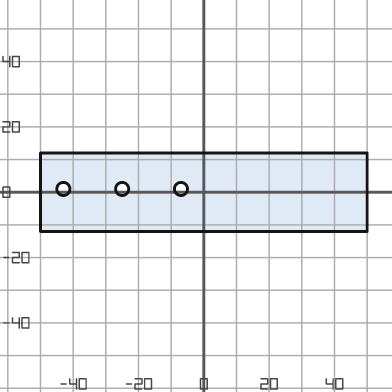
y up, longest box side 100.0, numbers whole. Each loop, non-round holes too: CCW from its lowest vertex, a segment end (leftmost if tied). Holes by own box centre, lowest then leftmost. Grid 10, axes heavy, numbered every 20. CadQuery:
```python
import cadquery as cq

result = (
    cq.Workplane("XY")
    .moveTo(-50.0, -12.0)
    .lineTo(50.0, -12.0)
    .lineTo(50.0, 12.0)
    .lineTo(-50.0, 12.0)
    .close()
    .moveTo(-43.0, 1.0)
    .circle(2.0)
    .moveTo(-25.0, 1.0)
    .circle(2.0)
    .moveTo(-7.0, 1.0)
    .circle(2.0)
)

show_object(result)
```